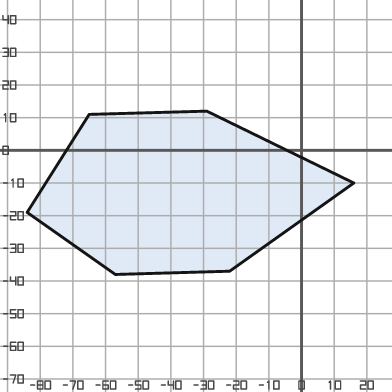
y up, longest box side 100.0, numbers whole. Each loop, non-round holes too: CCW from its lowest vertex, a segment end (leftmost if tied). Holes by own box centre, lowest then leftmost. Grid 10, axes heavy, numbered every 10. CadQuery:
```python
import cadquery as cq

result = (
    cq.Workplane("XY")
    .moveTo(-57.0, -38.0)
    .lineTo(-22.0, -37.0)
    .lineTo(16.0, -10.0)
    .lineTo(-29.0, 12.0)
    .lineTo(-65.0, 11.0)
    .lineTo(-84.0, -19.0)
    .close()
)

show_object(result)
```